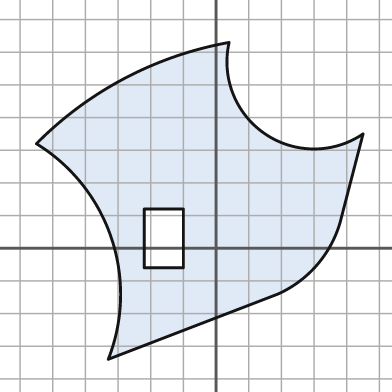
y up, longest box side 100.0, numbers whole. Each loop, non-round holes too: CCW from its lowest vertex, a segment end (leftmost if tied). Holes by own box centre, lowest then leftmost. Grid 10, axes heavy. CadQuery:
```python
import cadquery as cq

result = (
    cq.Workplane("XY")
    .moveTo(-33.0, -34.0)
    .lineTo(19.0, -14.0)
    .threePointArc((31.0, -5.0), (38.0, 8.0))
    .lineTo(45.0, 35.0)
    .threePointArc((15.0, 35.0), (4.0, 63.0))
    .threePointArc((-28.0, 52.0), (-55.0, 32.0))
    .threePointArc((-32.0, 3.0), (-33.0, -34.0))
    .close()
    .moveTo(-22.0, -6.0)
    .lineTo(-10.0, -6.0)
    .lineTo(-10.0, 12.0)
    .lineTo(-22.0, 12.0)
    .close()
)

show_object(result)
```